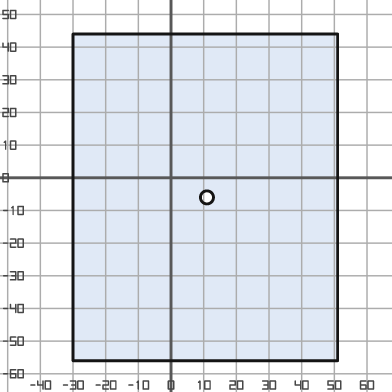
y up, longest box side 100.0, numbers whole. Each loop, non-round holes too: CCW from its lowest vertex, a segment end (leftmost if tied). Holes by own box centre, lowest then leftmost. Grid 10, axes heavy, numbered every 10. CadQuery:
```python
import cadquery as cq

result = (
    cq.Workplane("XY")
    .moveTo(-30.0, -56.0)
    .lineTo(51.0, -56.0)
    .lineTo(51.0, 44.0)
    .lineTo(-30.0, 44.0)
    .close()
    .moveTo(11.0, -6.0)
    .circle(2.0)
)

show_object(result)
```